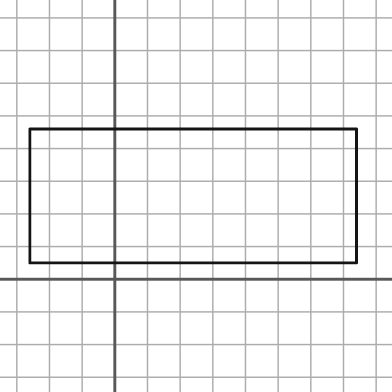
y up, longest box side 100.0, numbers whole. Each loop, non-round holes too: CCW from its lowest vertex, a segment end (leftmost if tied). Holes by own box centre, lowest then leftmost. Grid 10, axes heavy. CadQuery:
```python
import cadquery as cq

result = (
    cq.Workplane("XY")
    .moveTo(-26.0, 5.0)
    .lineTo(74.0, 5.0)
    .lineTo(74.0, 46.0)
    .lineTo(-26.0, 46.0)
    .close()
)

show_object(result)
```